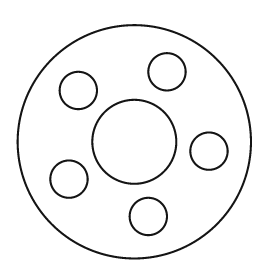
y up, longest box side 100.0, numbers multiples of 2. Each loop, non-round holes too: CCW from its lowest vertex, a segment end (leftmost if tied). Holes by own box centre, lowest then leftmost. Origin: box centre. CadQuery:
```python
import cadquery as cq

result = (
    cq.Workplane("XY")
    .moveTo(0.0, 0.0)
    .circle(50.0)
    .moveTo(6.0, -32.0)
    .circle(8.0)
    .moveTo(-28.0, -16.0)
    .circle(8.0)
    .moveTo(32.0, -4.0)
    .circle(8.0)
    .moveTo(0.0, 0.0)
    .circle(18.0)
    .moveTo(-24.0, 22.0)
    .circle(8.0)
    .moveTo(14.0, 30.0)
    .circle(8.0)
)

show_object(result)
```